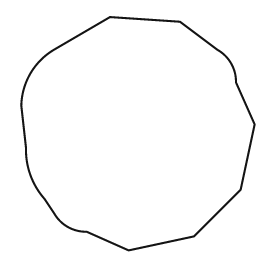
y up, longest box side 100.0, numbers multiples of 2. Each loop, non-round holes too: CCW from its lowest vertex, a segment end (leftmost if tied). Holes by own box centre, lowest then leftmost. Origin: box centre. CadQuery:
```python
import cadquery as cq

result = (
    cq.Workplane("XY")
    .moveTo(-4.0, -50.0)
    .lineTo(24.0, -44.0)
    .lineTo(44.0, -24.0)
    .lineTo(50.0, 4.0)
    .lineTo(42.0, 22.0)
    .threePointArc((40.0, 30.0), (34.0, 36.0))
    .lineTo(18.0, 48.0)
    .lineTo(-12.0, 50.0)
    .lineTo(-36.0, 36.0)
    .threePointArc((-46.0, 26.0), (-50.0, 12.0))
    .lineTo(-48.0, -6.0)
    .threePointArc((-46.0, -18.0), (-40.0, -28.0))
    .lineTo(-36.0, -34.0)
    .threePointArc((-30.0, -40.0), (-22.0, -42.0))
    .close()
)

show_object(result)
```